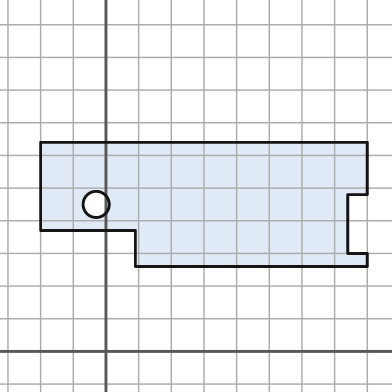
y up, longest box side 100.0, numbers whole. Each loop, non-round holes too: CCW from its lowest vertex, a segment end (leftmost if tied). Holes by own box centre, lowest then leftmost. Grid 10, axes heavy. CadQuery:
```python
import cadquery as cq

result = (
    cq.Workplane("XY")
    .moveTo(9.0, 26.0)
    .lineTo(80.0, 26.0)
    .lineTo(80.0, 30.0)
    .lineTo(74.0, 30.0)
    .lineTo(74.0, 48.0)
    .lineTo(80.0, 48.0)
    .lineTo(80.0, 64.0)
    .lineTo(-20.0, 64.0)
    .lineTo(-20.0, 37.0)
    .lineTo(9.0, 37.0)
    .close()
    .moveTo(-3.0, 45.0)
    .circle(4.0)
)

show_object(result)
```